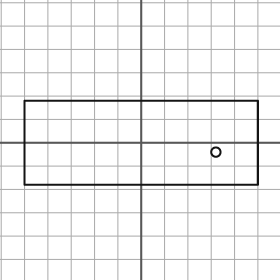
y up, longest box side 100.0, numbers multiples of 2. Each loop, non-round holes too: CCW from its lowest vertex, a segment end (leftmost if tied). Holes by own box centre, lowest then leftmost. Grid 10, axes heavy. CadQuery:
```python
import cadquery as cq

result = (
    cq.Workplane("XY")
    .moveTo(-50.0, -18.0)
    .lineTo(50.0, -18.0)
    .lineTo(50.0, 18.0)
    .lineTo(-50.0, 18.0)
    .close()
    .moveTo(32.0, -4.0)
    .circle(2.0)
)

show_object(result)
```